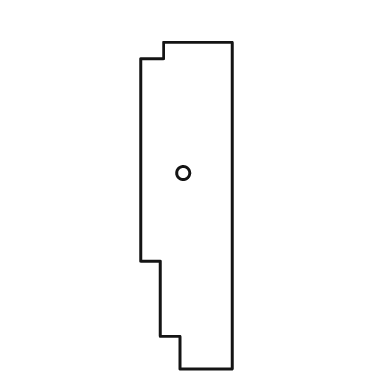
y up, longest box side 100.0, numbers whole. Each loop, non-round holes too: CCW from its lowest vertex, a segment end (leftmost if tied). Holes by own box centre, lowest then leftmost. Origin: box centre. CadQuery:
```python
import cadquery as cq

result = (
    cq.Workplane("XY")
    .moveTo(-2.0, -50.0)
    .lineTo(14.0, -50.0)
    .lineTo(14.0, 50.0)
    .lineTo(-7.0, 50.0)
    .lineTo(-7.0, 45.0)
    .lineTo(-14.0, 45.0)
    .lineTo(-14.0, -17.0)
    .lineTo(-8.0, -17.0)
    .lineTo(-8.0, -40.0)
    .lineTo(-2.0, -40.0)
    .close()
    .moveTo(-1.0, 10.0)
    .circle(2.0)
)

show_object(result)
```